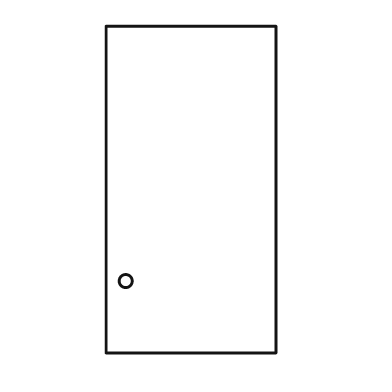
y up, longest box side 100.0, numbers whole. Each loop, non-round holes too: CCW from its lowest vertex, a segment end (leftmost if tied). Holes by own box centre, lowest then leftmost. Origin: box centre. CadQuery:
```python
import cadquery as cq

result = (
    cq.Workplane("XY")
    .moveTo(-26.0, -50.0)
    .lineTo(26.0, -50.0)
    .lineTo(26.0, 50.0)
    .lineTo(-26.0, 50.0)
    .close()
    .moveTo(-20.0, -28.0)
    .circle(2.0)
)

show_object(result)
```